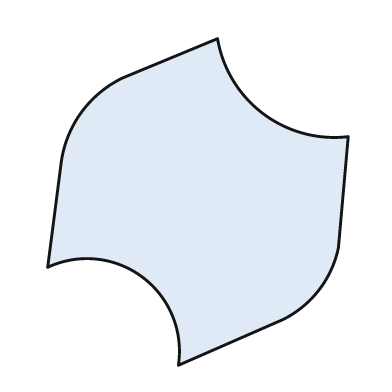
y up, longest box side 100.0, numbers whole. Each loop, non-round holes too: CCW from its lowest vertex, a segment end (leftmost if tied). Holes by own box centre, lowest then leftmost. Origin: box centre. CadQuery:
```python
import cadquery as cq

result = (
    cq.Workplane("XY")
    .moveTo(-6.0, -50.0)
    .lineTo(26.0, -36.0)
    .threePointArc((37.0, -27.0), (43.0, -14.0))
    .lineTo(46.0, 20.0)
    .threePointArc((20.0, 27.0), (6.0, 50.0))
    .lineTo(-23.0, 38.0)
    .threePointArc((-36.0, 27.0), (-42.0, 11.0))
    .lineTo(-46.0, -20.0)
    .threePointArc((-17.0, -23.0), (-6.0, -50.0))
    .close()
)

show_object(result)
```